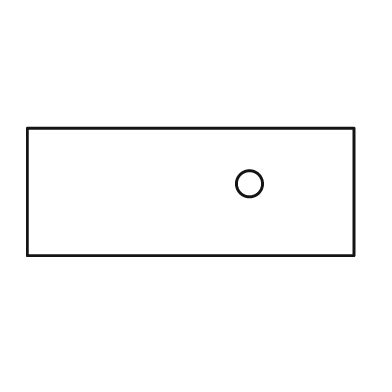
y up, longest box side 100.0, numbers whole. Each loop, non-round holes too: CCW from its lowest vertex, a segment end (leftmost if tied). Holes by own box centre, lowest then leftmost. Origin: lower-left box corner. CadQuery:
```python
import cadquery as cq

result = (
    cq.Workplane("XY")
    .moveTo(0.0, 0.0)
    .lineTo(100.0, 0.0)
    .lineTo(100.0, 39.0)
    .lineTo(0.0, 39.0)
    .close()
    .moveTo(68.0, 22.0)
    .circle(4.0)
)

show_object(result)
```